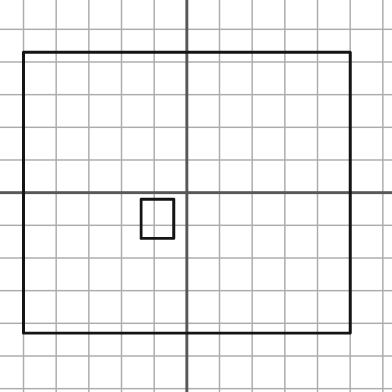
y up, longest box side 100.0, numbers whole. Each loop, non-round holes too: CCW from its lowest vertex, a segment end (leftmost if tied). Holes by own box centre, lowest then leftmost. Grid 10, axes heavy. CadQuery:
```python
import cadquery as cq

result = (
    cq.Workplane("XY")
    .moveTo(-50.0, -43.0)
    .lineTo(50.0, -43.0)
    .lineTo(50.0, 43.0)
    .lineTo(-50.0, 43.0)
    .close()
    .moveTo(-14.0, -14.0)
    .lineTo(-4.0, -14.0)
    .lineTo(-4.0, -2.0)
    .lineTo(-14.0, -2.0)
    .close()
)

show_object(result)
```